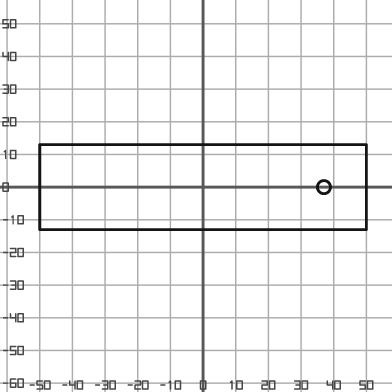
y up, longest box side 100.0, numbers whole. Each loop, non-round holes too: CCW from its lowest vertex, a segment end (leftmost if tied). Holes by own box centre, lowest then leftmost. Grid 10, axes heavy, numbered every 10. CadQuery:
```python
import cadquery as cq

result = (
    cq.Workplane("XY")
    .moveTo(-50.0, -13.0)
    .lineTo(50.0, -13.0)
    .lineTo(50.0, 13.0)
    .lineTo(-50.0, 13.0)
    .close()
    .moveTo(37.0, 0.0)
    .circle(2.0)
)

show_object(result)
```